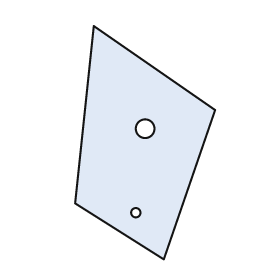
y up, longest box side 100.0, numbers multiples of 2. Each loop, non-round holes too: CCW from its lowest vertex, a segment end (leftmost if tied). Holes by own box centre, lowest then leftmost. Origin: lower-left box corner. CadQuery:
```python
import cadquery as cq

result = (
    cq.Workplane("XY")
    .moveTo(38.0, 0.0)
    .lineTo(60.0, 64.0)
    .lineTo(8.0, 100.0)
    .lineTo(0.0, 24.0)
    .close()
    .moveTo(26.0, 20.0)
    .circle(2.0)
    .moveTo(30.0, 56.0)
    .circle(4.0)
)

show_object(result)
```